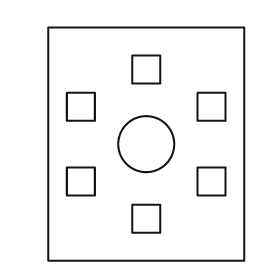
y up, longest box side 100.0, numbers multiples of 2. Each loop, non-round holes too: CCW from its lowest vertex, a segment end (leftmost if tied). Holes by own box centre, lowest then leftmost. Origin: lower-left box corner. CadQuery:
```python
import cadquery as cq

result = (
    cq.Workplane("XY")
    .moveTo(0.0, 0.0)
    .lineTo(84.0, 0.0)
    .lineTo(84.0, 100.0)
    .lineTo(0.0, 100.0)
    .close()
    .moveTo(36.0, 12.0)
    .lineTo(48.0, 12.0)
    .lineTo(48.0, 24.0)
    .lineTo(36.0, 24.0)
    .close()
    .moveTo(8.0, 28.0)
    .lineTo(20.0, 28.0)
    .lineTo(20.0, 40.0)
    .lineTo(8.0, 40.0)
    .close()
    .moveTo(64.0, 28.0)
    .lineTo(76.0, 28.0)
    .lineTo(76.0, 40.0)
    .lineTo(64.0, 40.0)
    .close()
    .moveTo(42.0, 50.0)
    .circle(12.0)
    .moveTo(8.0, 60.0)
    .lineTo(20.0, 60.0)
    .lineTo(20.0, 72.0)
    .lineTo(8.0, 72.0)
    .close()
    .moveTo(64.0, 60.0)
    .lineTo(76.0, 60.0)
    .lineTo(76.0, 72.0)
    .lineTo(64.0, 72.0)
    .close()
    .moveTo(36.0, 76.0)
    .lineTo(48.0, 76.0)
    .lineTo(48.0, 88.0)
    .lineTo(36.0, 88.0)
    .close()
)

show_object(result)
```